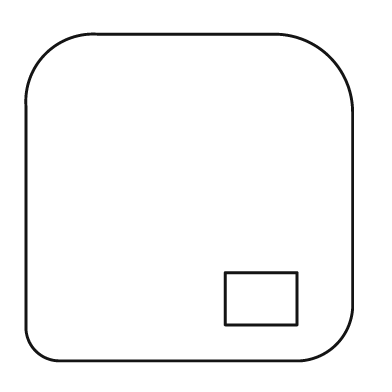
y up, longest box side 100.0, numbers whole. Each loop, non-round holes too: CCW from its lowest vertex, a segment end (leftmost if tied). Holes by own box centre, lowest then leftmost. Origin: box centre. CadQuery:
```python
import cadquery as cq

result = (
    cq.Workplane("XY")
    .moveTo(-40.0, -50.0)
    .lineTo(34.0, -50.0)
    .threePointArc((45.0, -45.0), (50.0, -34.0))
    .lineTo(50.0, 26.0)
    .threePointArc((43.0, 43.0), (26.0, 50.0))
    .lineTo(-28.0, 50.0)
    .threePointArc((-44.0, 44.0), (-50.0, 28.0))
    .lineTo(-50.0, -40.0)
    .threePointArc((-47.0, -47.0), (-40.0, -50.0))
    .close()
    .moveTo(11.0, -39.0)
    .lineTo(33.0, -39.0)
    .lineTo(33.0, -23.0)
    .lineTo(11.0, -23.0)
    .close()
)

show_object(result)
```